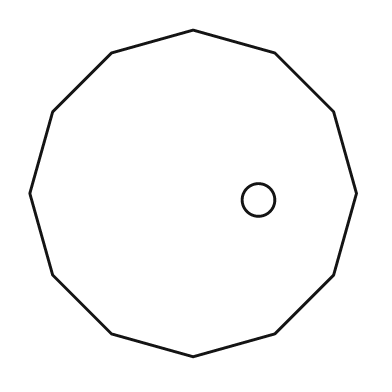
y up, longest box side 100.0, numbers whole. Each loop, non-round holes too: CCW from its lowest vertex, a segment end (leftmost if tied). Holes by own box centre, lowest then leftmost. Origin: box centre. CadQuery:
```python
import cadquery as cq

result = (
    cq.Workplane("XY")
    .moveTo(0.0, -50.0)
    .lineTo(25.0, -43.0)
    .lineTo(43.0, -25.0)
    .lineTo(50.0, 0.0)
    .lineTo(43.0, 25.0)
    .lineTo(25.0, 43.0)
    .lineTo(0.0, 50.0)
    .lineTo(-25.0, 43.0)
    .lineTo(-43.0, 25.0)
    .lineTo(-50.0, 0.0)
    .lineTo(-43.0, -25.0)
    .lineTo(-25.0, -43.0)
    .close()
    .moveTo(20.0, -2.0)
    .circle(5.0)
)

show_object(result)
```